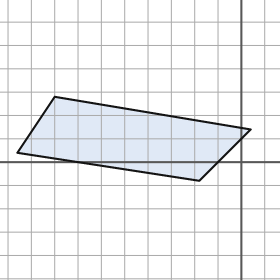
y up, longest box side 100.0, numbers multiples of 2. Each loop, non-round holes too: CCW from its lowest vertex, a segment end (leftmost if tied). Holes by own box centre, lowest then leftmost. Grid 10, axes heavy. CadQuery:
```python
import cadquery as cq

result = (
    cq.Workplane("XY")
    .moveTo(-18.0, -8.0)
    .lineTo(4.0, 14.0)
    .lineTo(-80.0, 28.0)
    .lineTo(-96.0, 4.0)
    .close()
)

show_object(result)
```